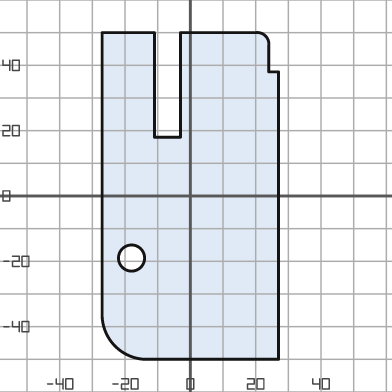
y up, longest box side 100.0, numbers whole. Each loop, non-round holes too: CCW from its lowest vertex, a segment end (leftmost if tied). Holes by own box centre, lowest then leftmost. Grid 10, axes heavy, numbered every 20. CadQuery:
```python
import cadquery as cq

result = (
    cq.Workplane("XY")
    .moveTo(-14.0, -50.0)
    .lineTo(27.0, -50.0)
    .lineTo(27.0, 38.0)
    .lineTo(24.0, 38.0)
    .lineTo(24.0, 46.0)
    .threePointArc((23.0, 49.0), (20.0, 50.0))
    .lineTo(-3.0, 50.0)
    .lineTo(-3.0, 18.0)
    .lineTo(-11.0, 18.0)
    .lineTo(-11.0, 50.0)
    .lineTo(-27.0, 50.0)
    .lineTo(-27.0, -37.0)
    .threePointArc((-23.0, -46.0), (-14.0, -50.0))
    .close()
    .moveTo(-18.0, -19.0)
    .circle(4.0)
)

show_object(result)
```